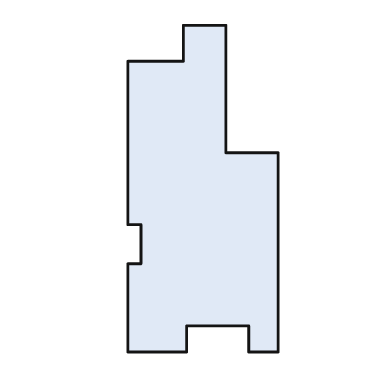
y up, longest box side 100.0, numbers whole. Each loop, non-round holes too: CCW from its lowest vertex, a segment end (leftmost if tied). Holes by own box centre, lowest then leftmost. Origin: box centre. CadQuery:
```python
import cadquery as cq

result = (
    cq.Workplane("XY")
    .moveTo(-23.0, -50.0)
    .lineTo(-5.0, -50.0)
    .lineTo(-5.0, -42.0)
    .lineTo(14.0, -42.0)
    .lineTo(14.0, -50.0)
    .lineTo(23.0, -50.0)
    .lineTo(23.0, 11.0)
    .lineTo(7.0, 11.0)
    .lineTo(7.0, 50.0)
    .lineTo(-6.0, 50.0)
    .lineTo(-6.0, 39.0)
    .lineTo(-23.0, 39.0)
    .lineTo(-23.0, -11.0)
    .lineTo(-19.0, -11.0)
    .lineTo(-19.0, -23.0)
    .lineTo(-23.0, -23.0)
    .close()
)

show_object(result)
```